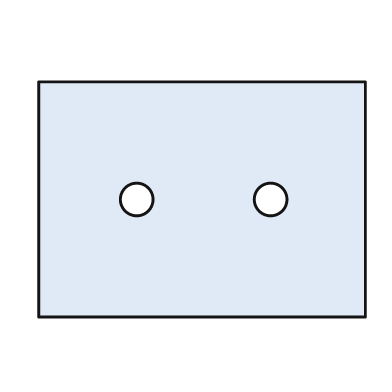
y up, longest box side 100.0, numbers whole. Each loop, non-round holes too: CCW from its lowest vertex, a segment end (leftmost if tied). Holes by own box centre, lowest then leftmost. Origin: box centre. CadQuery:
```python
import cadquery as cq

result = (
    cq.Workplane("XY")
    .moveTo(-50.0, -36.0)
    .lineTo(50.0, -36.0)
    .lineTo(50.0, 36.0)
    .lineTo(-50.0, 36.0)
    .close()
    .moveTo(-20.0, 0.0)
    .circle(5.0)
    .moveTo(21.0, 0.0)
    .circle(5.0)
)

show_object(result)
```